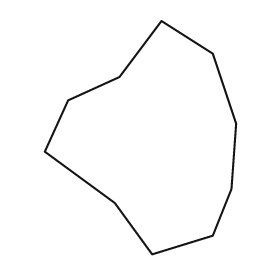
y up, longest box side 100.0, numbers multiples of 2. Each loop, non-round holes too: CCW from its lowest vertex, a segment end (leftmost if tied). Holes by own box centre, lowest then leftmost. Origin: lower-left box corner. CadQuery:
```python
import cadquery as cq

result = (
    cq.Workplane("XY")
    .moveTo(46.0, 0.0)
    .lineTo(72.0, 8.0)
    .lineTo(80.0, 28.0)
    .lineTo(82.0, 56.0)
    .lineTo(72.0, 86.0)
    .lineTo(50.0, 100.0)
    .lineTo(32.0, 76.0)
    .lineTo(10.0, 66.0)
    .lineTo(0.0, 44.0)
    .lineTo(30.0, 22.0)
    .close()
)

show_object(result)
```